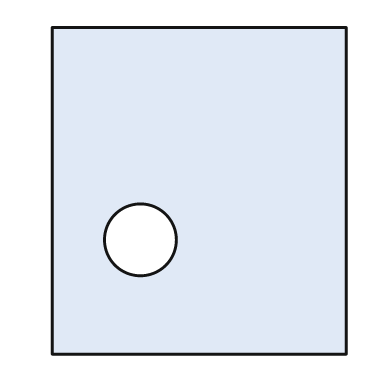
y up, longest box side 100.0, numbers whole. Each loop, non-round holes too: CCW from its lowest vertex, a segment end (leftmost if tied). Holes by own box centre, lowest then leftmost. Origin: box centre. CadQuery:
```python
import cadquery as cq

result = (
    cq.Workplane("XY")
    .moveTo(-45.0, -50.0)
    .lineTo(45.0, -50.0)
    .lineTo(45.0, 50.0)
    .lineTo(-45.0, 50.0)
    .close()
    .moveTo(-18.0, -15.0)
    .circle(11.0)
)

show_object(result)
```